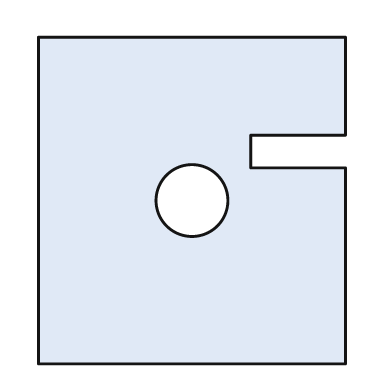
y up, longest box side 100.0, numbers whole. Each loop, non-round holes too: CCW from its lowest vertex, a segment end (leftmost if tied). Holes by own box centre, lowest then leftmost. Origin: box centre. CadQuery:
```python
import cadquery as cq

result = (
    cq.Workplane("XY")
    .moveTo(-47.0, -50.0)
    .lineTo(47.0, -50.0)
    .lineTo(47.0, 10.0)
    .lineTo(18.0, 10.0)
    .lineTo(18.0, 20.0)
    .lineTo(47.0, 20.0)
    .lineTo(47.0, 50.0)
    .lineTo(-47.0, 50.0)
    .close()
    .moveTo(0.0, 0.0)
    .circle(11.0)
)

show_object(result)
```